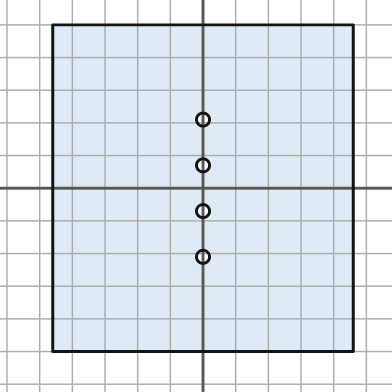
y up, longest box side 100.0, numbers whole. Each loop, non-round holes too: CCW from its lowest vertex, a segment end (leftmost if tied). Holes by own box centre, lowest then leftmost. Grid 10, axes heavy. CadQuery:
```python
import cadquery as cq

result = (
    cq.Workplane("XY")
    .moveTo(-46.0, -50.0)
    .lineTo(46.0, -50.0)
    .lineTo(46.0, 50.0)
    .lineTo(-46.0, 50.0)
    .close()
    .moveTo(0.0, -21.0)
    .circle(2.0)
    .moveTo(0.0, -7.0)
    .circle(2.0)
    .moveTo(0.0, 7.0)
    .circle(2.0)
    .moveTo(0.0, 21.0)
    .circle(2.0)
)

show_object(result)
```